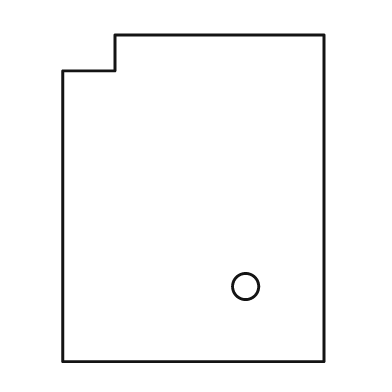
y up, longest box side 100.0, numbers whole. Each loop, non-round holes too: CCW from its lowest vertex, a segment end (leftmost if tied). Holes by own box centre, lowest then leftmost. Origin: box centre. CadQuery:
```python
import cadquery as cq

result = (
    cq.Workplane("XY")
    .moveTo(-40.0, -50.0)
    .lineTo(40.0, -50.0)
    .lineTo(40.0, 50.0)
    .lineTo(-24.0, 50.0)
    .lineTo(-24.0, 39.0)
    .lineTo(-40.0, 39.0)
    .close()
    .moveTo(16.0, -27.0)
    .circle(4.0)
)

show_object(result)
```